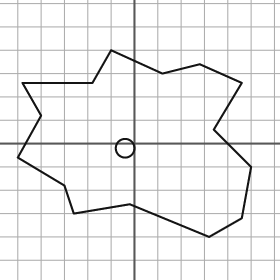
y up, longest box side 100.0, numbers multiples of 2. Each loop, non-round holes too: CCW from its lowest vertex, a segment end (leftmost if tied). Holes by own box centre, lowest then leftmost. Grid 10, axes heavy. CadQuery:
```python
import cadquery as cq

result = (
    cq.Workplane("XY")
    .moveTo(32.0, -40.0)
    .lineTo(46.0, -32.0)
    .lineTo(50.0, -10.0)
    .lineTo(34.0, 6.0)
    .lineTo(46.0, 26.0)
    .lineTo(28.0, 34.0)
    .lineTo(12.0, 30.0)
    .lineTo(-10.0, 40.0)
    .lineTo(-18.0, 26.0)
    .lineTo(-48.0, 26.0)
    .lineTo(-40.0, 12.0)
    .lineTo(-50.0, -6.0)
    .lineTo(-30.0, -18.0)
    .lineTo(-26.0, -30.0)
    .lineTo(-2.0, -26.0)
    .close()
    .moveTo(-4.0, -2.0)
    .circle(4.0)
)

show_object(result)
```